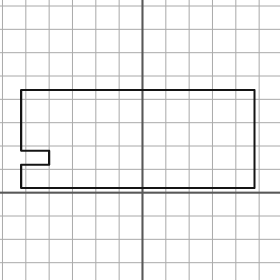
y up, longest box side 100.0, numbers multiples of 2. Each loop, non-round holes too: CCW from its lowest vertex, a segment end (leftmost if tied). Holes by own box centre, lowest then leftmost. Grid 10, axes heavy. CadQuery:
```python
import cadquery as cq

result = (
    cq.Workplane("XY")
    .moveTo(-52.0, 2.0)
    .lineTo(48.0, 2.0)
    .lineTo(48.0, 44.0)
    .lineTo(-52.0, 44.0)
    .lineTo(-52.0, 18.0)
    .lineTo(-40.0, 18.0)
    .lineTo(-40.0, 12.0)
    .lineTo(-52.0, 12.0)
    .close()
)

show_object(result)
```